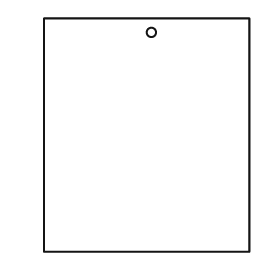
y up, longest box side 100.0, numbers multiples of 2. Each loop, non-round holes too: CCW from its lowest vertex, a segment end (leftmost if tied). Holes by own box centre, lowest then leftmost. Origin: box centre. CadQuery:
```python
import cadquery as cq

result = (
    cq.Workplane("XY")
    .moveTo(-44.0, -50.0)
    .lineTo(44.0, -50.0)
    .lineTo(44.0, 50.0)
    .lineTo(-44.0, 50.0)
    .close()
    .moveTo(2.0, 44.0)
    .circle(2.0)
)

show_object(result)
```